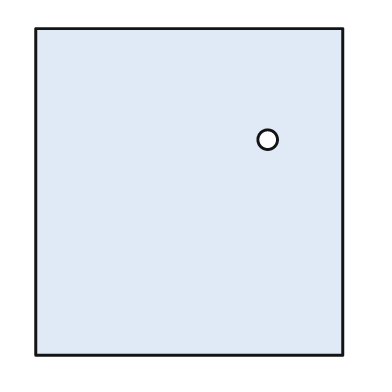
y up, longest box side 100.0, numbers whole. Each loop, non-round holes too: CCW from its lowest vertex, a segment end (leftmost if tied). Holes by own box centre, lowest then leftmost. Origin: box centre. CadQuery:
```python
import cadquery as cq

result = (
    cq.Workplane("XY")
    .moveTo(-47.0, -50.0)
    .lineTo(47.0, -50.0)
    .lineTo(47.0, 50.0)
    .lineTo(-47.0, 50.0)
    .close()
    .moveTo(24.0, 16.0)
    .circle(3.0)
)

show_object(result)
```